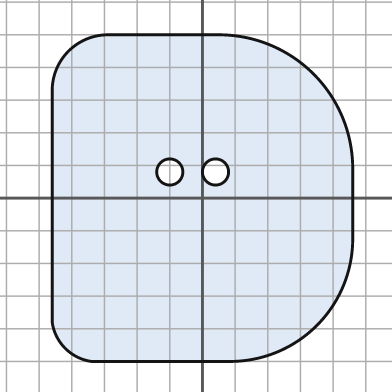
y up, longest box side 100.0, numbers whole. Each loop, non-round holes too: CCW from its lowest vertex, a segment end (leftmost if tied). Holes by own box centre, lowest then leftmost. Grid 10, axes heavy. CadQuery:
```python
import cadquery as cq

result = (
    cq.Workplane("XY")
    .moveTo(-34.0, -50.0)
    .lineTo(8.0, -50.0)
    .threePointArc((35.0, -39.0), (46.0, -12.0))
    .lineTo(46.0, 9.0)
    .threePointArc((34.0, 38.0), (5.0, 50.0))
    .lineTo(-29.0, 50.0)
    .threePointArc((-41.0, 45.0), (-46.0, 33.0))
    .lineTo(-46.0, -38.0)
    .threePointArc((-42.0, -46.0), (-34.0, -50.0))
    .close()
    .moveTo(-10.0, 8.0)
    .circle(4.0)
    .moveTo(4.0, 8.0)
    .circle(4.0)
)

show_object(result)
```